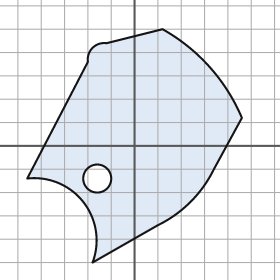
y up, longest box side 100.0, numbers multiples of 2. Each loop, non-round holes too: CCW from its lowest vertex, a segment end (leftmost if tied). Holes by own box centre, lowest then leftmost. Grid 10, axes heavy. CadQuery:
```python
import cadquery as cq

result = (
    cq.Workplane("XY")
    .moveTo(-18.0, -50.0)
    .lineTo(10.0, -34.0)
    .threePointArc((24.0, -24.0), (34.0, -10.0))
    .lineTo(46.0, 12.0)
    .threePointArc((32.0, 34.0), (12.0, 50.0))
    .lineTo(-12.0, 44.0)
    .threePointArc((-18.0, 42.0), (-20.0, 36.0))
    .lineTo(-46.0, -14.0)
    .threePointArc((-22.0, -24.0), (-18.0, -50.0))
    .close()
    .moveTo(-16.0, -14.0)
    .circle(6.0)
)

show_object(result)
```